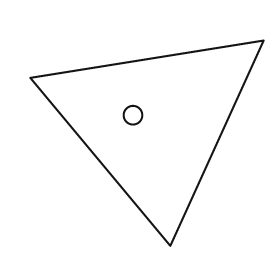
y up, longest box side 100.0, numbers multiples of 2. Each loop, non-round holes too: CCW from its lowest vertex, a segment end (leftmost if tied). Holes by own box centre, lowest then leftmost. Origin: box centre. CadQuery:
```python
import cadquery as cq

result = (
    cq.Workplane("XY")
    .moveTo(10.0, -44.0)
    .lineTo(50.0, 44.0)
    .lineTo(-50.0, 28.0)
    .close()
    .moveTo(-6.0, 12.0)
    .circle(4.0)
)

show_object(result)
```